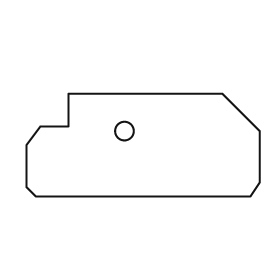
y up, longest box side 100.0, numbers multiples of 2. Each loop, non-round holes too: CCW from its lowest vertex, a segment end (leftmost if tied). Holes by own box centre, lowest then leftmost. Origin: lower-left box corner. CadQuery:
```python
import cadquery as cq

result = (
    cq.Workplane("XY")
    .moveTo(4.0, 0.0)
    .lineTo(96.0, 0.0)
    .lineTo(100.0, 6.0)
    .lineTo(100.0, 28.0)
    .lineTo(84.0, 44.0)
    .lineTo(18.0, 44.0)
    .lineTo(18.0, 30.0)
    .lineTo(6.0, 30.0)
    .lineTo(0.0, 22.0)
    .lineTo(0.0, 4.0)
    .close()
    .moveTo(42.0, 28.0)
    .circle(4.0)
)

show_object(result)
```